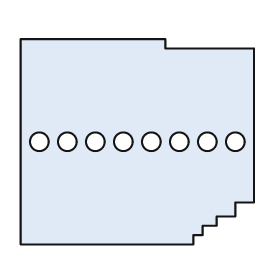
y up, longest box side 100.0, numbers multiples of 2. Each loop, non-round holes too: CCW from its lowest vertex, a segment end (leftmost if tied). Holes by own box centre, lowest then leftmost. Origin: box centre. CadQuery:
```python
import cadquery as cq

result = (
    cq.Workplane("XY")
    .moveTo(-50.0, -44.0)
    .lineTo(24.0, -44.0)
    .lineTo(24.0, -40.0)
    .lineTo(28.0, -40.0)
    .lineTo(28.0, -36.0)
    .lineTo(34.0, -36.0)
    .lineTo(34.0, -32.0)
    .lineTo(42.0, -32.0)
    .lineTo(42.0, -26.0)
    .lineTo(50.0, -26.0)
    .lineTo(50.0, 40.0)
    .lineTo(12.0, 40.0)
    .lineTo(12.0, 44.0)
    .lineTo(-50.0, 44.0)
    .close()
    .moveTo(-42.0, 0.0)
    .circle(4.0)
    .moveTo(-30.0, 0.0)
    .circle(4.0)
    .moveTo(-18.0, 0.0)
    .circle(4.0)
    .moveTo(-6.0, 0.0)
    .circle(4.0)
    .moveTo(6.0, 0.0)
    .circle(4.0)
    .moveTo(18.0, 0.0)
    .circle(4.0)
    .moveTo(30.0, 0.0)
    .circle(4.0)
    .moveTo(42.0, 0.0)
    .circle(4.0)
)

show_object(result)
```